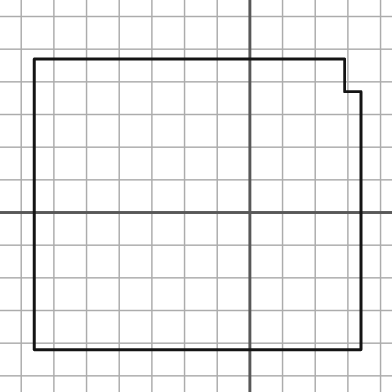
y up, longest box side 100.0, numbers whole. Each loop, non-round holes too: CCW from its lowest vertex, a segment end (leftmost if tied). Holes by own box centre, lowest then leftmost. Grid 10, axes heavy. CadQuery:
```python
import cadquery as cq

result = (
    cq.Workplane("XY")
    .moveTo(-66.0, -42.0)
    .lineTo(34.0, -42.0)
    .lineTo(34.0, 37.0)
    .lineTo(29.0, 37.0)
    .lineTo(29.0, 47.0)
    .lineTo(-66.0, 47.0)
    .close()
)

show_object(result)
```